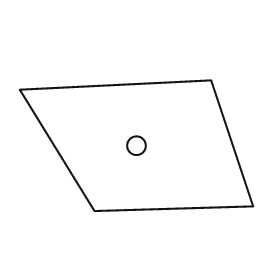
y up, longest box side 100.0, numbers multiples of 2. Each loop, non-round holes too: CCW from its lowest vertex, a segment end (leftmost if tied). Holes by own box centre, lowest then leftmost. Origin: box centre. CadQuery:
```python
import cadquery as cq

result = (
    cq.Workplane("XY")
    .moveTo(-18.0, -28.0)
    .lineTo(50.0, -26.0)
    .lineTo(32.0, 28.0)
    .lineTo(-50.0, 24.0)
    .close()
    .moveTo(0.0, 0.0)
    .circle(4.0)
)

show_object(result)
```